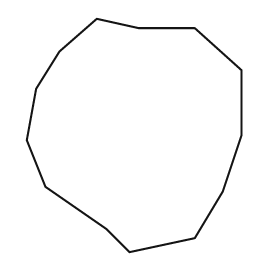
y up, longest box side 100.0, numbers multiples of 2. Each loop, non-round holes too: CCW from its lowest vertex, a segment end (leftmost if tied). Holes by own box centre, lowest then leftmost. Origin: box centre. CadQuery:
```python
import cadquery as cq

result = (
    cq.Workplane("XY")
    .moveTo(-2.0, -50.0)
    .lineTo(26.0, -44.0)
    .lineTo(38.0, -24.0)
    .lineTo(46.0, 0.0)
    .lineTo(46.0, 28.0)
    .lineTo(26.0, 46.0)
    .lineTo(2.0, 46.0)
    .lineTo(-16.0, 50.0)
    .lineTo(-32.0, 36.0)
    .lineTo(-42.0, 20.0)
    .lineTo(-46.0, -2.0)
    .lineTo(-38.0, -22.0)
    .lineTo(-12.0, -40.0)
    .close()
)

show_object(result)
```